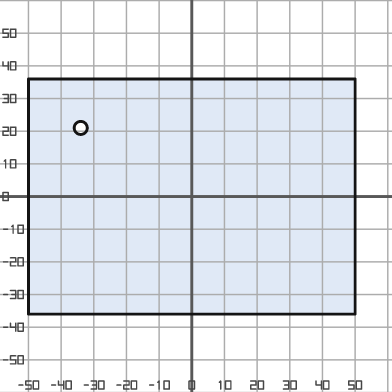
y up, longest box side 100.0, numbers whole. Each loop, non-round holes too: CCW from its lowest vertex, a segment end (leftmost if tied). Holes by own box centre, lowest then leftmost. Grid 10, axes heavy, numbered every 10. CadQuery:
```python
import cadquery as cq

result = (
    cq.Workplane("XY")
    .moveTo(-50.0, -36.0)
    .lineTo(50.0, -36.0)
    .lineTo(50.0, 36.0)
    .lineTo(-50.0, 36.0)
    .close()
    .moveTo(-34.0, 21.0)
    .circle(2.0)
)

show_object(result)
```